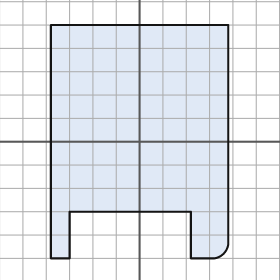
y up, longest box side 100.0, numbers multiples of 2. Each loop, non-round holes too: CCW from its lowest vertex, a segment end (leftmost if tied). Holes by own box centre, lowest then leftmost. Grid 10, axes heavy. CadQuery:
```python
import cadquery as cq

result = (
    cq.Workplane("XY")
    .moveTo(-38.0, -50.0)
    .lineTo(-30.0, -50.0)
    .lineTo(-30.0, -30.0)
    .lineTo(22.0, -30.0)
    .lineTo(22.0, -50.0)
    .lineTo(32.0, -50.0)
    .threePointArc((36.0, -48.0), (38.0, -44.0))
    .lineTo(38.0, 50.0)
    .lineTo(-38.0, 50.0)
    .close()
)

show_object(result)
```